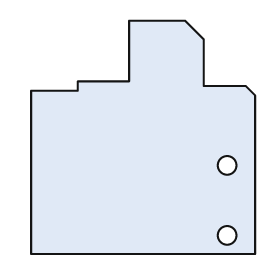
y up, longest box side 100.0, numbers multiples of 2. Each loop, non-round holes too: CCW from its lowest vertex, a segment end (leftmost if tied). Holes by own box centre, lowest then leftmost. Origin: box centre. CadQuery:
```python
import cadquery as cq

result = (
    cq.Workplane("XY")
    .moveTo(-48.0, -50.0)
    .lineTo(48.0, -50.0)
    .lineTo(48.0, 18.0)
    .lineTo(44.0, 22.0)
    .lineTo(26.0, 22.0)
    .lineTo(26.0, 42.0)
    .lineTo(18.0, 50.0)
    .lineTo(-6.0, 50.0)
    .lineTo(-6.0, 24.0)
    .lineTo(-28.0, 24.0)
    .lineTo(-28.0, 20.0)
    .lineTo(-48.0, 20.0)
    .close()
    .moveTo(36.0, -42.0)
    .circle(4.0)
    .moveTo(36.0, -12.0)
    .circle(4.0)
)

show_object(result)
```